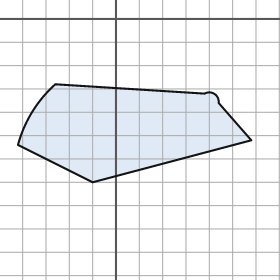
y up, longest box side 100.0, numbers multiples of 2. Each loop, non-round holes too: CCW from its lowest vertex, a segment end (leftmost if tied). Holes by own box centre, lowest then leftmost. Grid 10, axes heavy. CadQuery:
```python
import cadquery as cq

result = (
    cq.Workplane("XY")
    .moveTo(-10.0, -70.0)
    .lineTo(58.0, -52.0)
    .lineTo(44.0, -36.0)
    .threePointArc((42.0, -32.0), (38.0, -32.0))
    .lineTo(-26.0, -28.0)
    .threePointArc((-36.0, -40.0), (-42.0, -54.0))
    .close()
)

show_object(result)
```